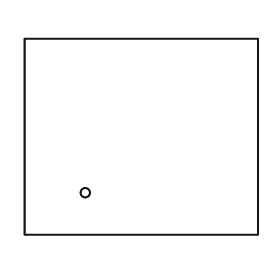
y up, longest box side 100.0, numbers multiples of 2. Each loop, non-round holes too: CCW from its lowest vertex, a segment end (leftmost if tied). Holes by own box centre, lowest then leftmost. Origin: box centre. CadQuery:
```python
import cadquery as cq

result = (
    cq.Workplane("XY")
    .moveTo(-50.0, -42.0)
    .lineTo(50.0, -42.0)
    .lineTo(50.0, 42.0)
    .lineTo(-50.0, 42.0)
    .close()
    .moveTo(-24.0, -24.0)
    .circle(2.0)
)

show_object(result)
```